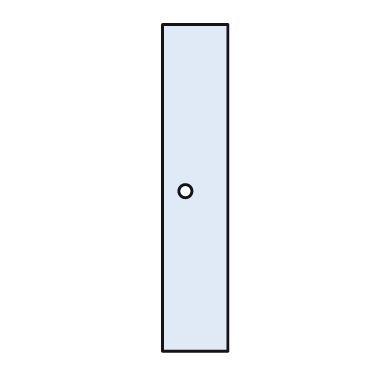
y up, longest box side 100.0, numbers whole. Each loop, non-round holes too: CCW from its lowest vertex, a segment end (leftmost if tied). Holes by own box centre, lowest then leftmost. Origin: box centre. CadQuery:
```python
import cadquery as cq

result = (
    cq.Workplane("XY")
    .moveTo(-10.0, -50.0)
    .lineTo(10.0, -50.0)
    .lineTo(10.0, 50.0)
    .lineTo(-10.0, 50.0)
    .close()
    .moveTo(-3.0, -1.0)
    .circle(2.0)
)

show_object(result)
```